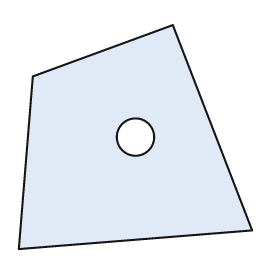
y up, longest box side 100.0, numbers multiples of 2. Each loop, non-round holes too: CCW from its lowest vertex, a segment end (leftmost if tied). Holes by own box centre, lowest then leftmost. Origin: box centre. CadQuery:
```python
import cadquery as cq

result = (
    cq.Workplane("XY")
    .moveTo(-50.0, -48.0)
    .lineTo(50.0, -40.0)
    .lineTo(16.0, 48.0)
    .lineTo(-44.0, 26.0)
    .close()
    .moveTo(0.0, 0.0)
    .circle(8.0)
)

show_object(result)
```